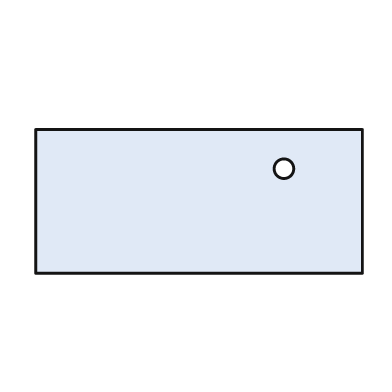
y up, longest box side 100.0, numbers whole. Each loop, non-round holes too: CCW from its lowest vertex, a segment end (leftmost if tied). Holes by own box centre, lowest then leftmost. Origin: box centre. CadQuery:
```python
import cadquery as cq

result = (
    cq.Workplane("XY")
    .moveTo(-50.0, -22.0)
    .lineTo(50.0, -22.0)
    .lineTo(50.0, 22.0)
    .lineTo(-50.0, 22.0)
    .close()
    .moveTo(26.0, 10.0)
    .circle(3.0)
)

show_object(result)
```